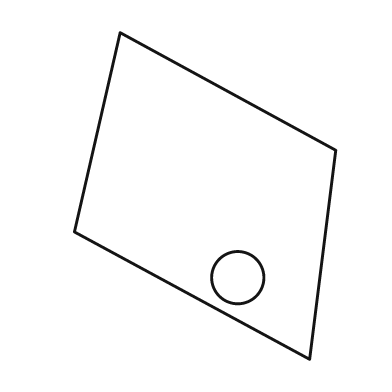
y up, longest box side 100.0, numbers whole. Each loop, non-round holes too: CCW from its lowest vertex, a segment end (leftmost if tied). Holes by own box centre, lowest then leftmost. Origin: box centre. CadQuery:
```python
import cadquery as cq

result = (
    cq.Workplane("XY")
    .moveTo(32.0, -50.0)
    .lineTo(40.0, 14.0)
    .lineTo(-26.0, 50.0)
    .lineTo(-40.0, -11.0)
    .close()
    .moveTo(10.0, -25.0)
    .circle(8.0)
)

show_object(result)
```